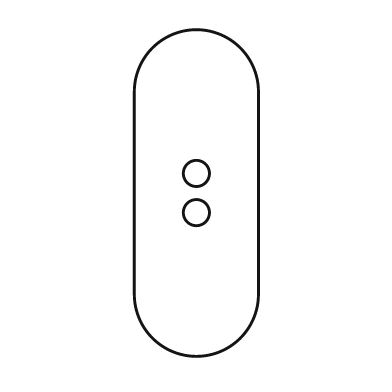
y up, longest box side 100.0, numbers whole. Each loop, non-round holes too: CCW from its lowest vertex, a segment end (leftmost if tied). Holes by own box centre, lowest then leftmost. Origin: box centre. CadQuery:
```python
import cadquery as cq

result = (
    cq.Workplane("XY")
    .moveTo(-19.0, -31.0)
    .threePointArc((0.0, -50.0), (19.0, -31.0))
    .lineTo(19.0, 31.0)
    .threePointArc((0.0, 50.0), (-19.0, 31.0))
    .close()
    .moveTo(0.0, -6.0)
    .circle(4.0)
    .moveTo(0.0, 6.0)
    .circle(4.0)
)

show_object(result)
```